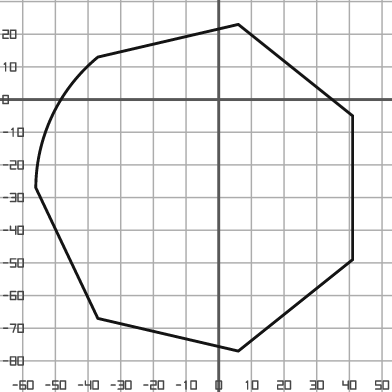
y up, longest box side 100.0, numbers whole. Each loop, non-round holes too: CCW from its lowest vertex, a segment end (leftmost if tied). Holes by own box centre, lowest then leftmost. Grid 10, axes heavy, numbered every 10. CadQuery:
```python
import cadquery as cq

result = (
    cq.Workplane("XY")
    .moveTo(6.0, -77.0)
    .lineTo(41.0, -49.0)
    .lineTo(41.0, -5.0)
    .lineTo(6.0, 23.0)
    .lineTo(-37.0, 13.0)
    .threePointArc((-51.0, -5.0), (-56.0, -27.0))
    .lineTo(-37.0, -67.0)
    .close()
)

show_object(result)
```